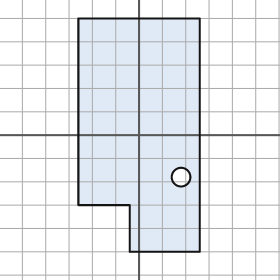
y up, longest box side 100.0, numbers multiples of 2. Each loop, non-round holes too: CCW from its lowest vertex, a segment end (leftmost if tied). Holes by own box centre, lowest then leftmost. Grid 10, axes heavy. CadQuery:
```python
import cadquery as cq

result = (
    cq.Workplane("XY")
    .moveTo(-4.0, -50.0)
    .lineTo(26.0, -50.0)
    .lineTo(26.0, 50.0)
    .lineTo(-26.0, 50.0)
    .lineTo(-26.0, -30.0)
    .lineTo(-4.0, -30.0)
    .close()
    .moveTo(18.0, -18.0)
    .circle(4.0)
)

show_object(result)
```